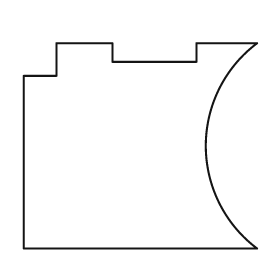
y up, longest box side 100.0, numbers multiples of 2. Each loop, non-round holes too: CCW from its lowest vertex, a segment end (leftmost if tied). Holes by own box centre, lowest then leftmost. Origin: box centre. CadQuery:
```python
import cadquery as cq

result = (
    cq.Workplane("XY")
    .moveTo(-50.0, -44.0)
    .lineTo(50.0, -44.0)
    .threePointArc((28.0, 0.0), (50.0, 44.0))
    .lineTo(24.0, 44.0)
    .lineTo(24.0, 36.0)
    .lineTo(-12.0, 36.0)
    .lineTo(-12.0, 44.0)
    .lineTo(-36.0, 44.0)
    .lineTo(-36.0, 30.0)
    .lineTo(-50.0, 30.0)
    .close()
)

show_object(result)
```